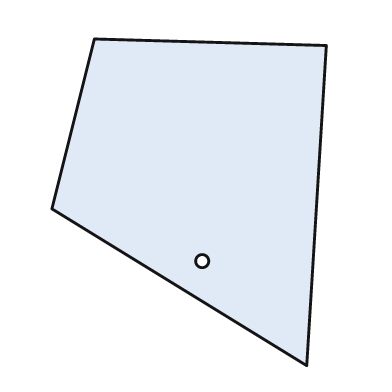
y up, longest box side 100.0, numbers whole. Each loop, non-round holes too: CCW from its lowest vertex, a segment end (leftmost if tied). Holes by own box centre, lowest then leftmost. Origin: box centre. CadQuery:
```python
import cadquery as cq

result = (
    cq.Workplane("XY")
    .moveTo(36.0, -50.0)
    .lineTo(42.0, 48.0)
    .lineTo(-29.0, 50.0)
    .lineTo(-42.0, -2.0)
    .close()
    .moveTo(4.0, -18.0)
    .circle(2.0)
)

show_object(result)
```